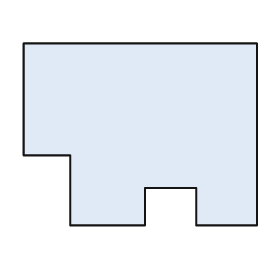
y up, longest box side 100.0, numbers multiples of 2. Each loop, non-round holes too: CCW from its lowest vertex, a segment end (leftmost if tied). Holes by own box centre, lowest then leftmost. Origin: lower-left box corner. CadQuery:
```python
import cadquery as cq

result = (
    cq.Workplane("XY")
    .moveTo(20.0, 0.0)
    .lineTo(52.0, 0.0)
    .lineTo(52.0, 16.0)
    .lineTo(74.0, 16.0)
    .lineTo(74.0, 0.0)
    .lineTo(100.0, 0.0)
    .lineTo(100.0, 78.0)
    .lineTo(0.0, 78.0)
    .lineTo(0.0, 30.0)
    .lineTo(20.0, 30.0)
    .close()
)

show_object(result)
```